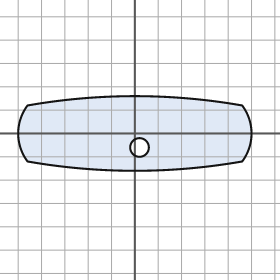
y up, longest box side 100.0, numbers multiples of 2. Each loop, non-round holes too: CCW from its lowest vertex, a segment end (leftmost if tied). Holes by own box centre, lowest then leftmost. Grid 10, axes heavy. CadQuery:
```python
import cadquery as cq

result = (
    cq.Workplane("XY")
    .moveTo(-46.0, -12.0)
    .threePointArc((0.0, -16.0), (46.0, -12.0))
    .threePointArc((50.0, 0.0), (46.0, 12.0))
    .threePointArc((0.0, 16.0), (-46.0, 12.0))
    .threePointArc((-50.0, 0.0), (-46.0, -12.0))
    .close()
    .moveTo(2.0, -6.0)
    .circle(4.0)
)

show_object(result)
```